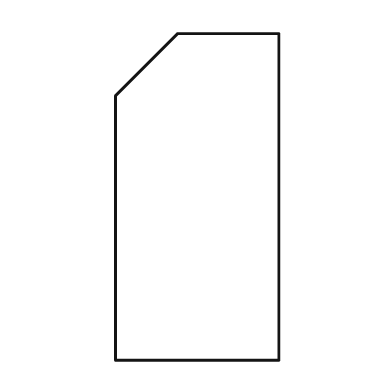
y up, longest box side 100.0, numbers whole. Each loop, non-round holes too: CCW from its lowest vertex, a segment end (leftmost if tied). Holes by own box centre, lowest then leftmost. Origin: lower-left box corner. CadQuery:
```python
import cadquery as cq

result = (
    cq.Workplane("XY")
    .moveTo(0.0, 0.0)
    .lineTo(50.0, 0.0)
    .lineTo(50.0, 100.0)
    .lineTo(19.0, 100.0)
    .lineTo(0.0, 81.0)
    .close()
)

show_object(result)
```